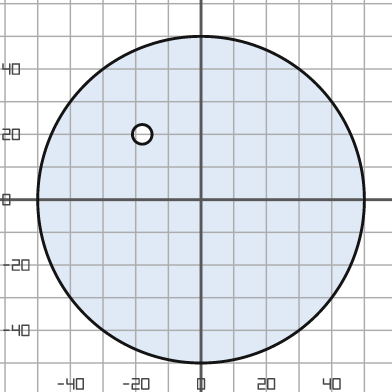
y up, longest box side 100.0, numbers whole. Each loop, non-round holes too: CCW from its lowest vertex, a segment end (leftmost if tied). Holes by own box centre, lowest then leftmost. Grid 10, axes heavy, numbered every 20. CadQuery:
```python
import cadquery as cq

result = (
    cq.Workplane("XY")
    .moveTo(0.0, 0.0)
    .circle(50.0)
    .moveTo(-18.0, 20.0)
    .circle(3.0)
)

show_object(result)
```